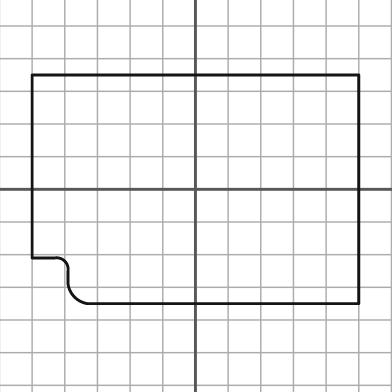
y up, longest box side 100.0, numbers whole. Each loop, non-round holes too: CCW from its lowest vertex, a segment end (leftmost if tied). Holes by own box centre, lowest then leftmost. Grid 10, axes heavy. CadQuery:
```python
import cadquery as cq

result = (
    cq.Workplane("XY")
    .moveTo(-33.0, -35.0)
    .lineTo(50.0, -35.0)
    .lineTo(50.0, 35.0)
    .lineTo(-50.0, 35.0)
    .lineTo(-50.0, -21.0)
    .lineTo(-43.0, -21.0)
    .threePointArc((-40.0, -22.0), (-39.0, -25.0))
    .lineTo(-39.0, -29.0)
    .threePointArc((-37.0, -33.0), (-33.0, -35.0))
    .close()
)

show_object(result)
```